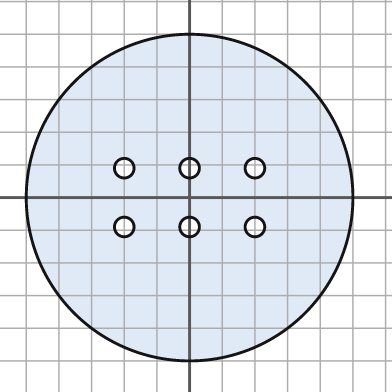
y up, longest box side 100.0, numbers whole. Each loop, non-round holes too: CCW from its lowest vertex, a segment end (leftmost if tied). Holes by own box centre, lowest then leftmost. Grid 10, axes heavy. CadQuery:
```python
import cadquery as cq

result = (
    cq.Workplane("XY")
    .moveTo(0.0, 0.0)
    .circle(50.0)
    .moveTo(-20.0, -9.0)
    .circle(3.0)
    .moveTo(0.0, -9.0)
    .circle(3.0)
    .moveTo(20.0, -9.0)
    .circle(3.0)
    .moveTo(-20.0, 9.0)
    .circle(3.0)
    .moveTo(0.0, 9.0)
    .circle(3.0)
    .moveTo(20.0, 9.0)
    .circle(3.0)
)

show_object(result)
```